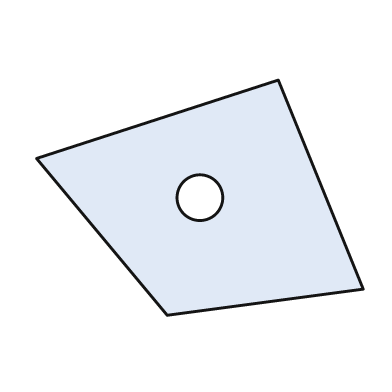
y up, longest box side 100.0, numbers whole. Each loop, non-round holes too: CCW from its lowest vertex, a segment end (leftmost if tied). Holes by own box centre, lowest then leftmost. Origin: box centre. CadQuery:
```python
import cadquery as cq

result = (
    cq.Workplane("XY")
    .moveTo(-10.0, -36.0)
    .lineTo(50.0, -28.0)
    .lineTo(24.0, 36.0)
    .lineTo(-50.0, 12.0)
    .close()
    .moveTo(0.0, 0.0)
    .circle(7.0)
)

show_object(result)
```